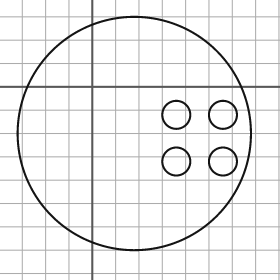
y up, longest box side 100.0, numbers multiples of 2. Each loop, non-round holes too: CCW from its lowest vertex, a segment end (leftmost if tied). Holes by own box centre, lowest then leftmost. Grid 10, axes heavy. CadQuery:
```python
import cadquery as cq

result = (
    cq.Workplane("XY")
    .moveTo(18.0, -20.0)
    .circle(50.0)
    .moveTo(36.0, -32.0)
    .circle(6.0)
    .moveTo(56.0, -32.0)
    .circle(6.0)
    .moveTo(36.0, -12.0)
    .circle(6.0)
    .moveTo(56.0, -12.0)
    .circle(6.0)
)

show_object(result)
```